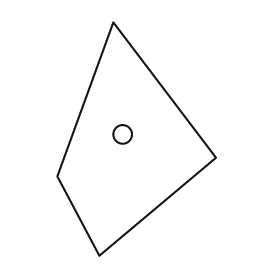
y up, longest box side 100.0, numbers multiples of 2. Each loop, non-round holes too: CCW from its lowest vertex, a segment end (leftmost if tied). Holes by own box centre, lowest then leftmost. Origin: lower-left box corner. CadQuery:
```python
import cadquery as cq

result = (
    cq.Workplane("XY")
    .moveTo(18.0, 0.0)
    .lineTo(68.0, 42.0)
    .lineTo(24.0, 100.0)
    .lineTo(0.0, 34.0)
    .close()
    .moveTo(28.0, 52.0)
    .circle(4.0)
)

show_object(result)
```